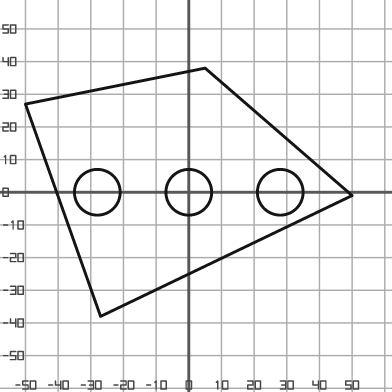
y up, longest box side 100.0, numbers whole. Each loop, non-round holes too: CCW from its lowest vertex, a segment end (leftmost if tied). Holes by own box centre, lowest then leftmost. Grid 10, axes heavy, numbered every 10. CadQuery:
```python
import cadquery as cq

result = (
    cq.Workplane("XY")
    .moveTo(-27.0, -38.0)
    .lineTo(50.0, -1.0)
    .lineTo(5.0, 38.0)
    .lineTo(-50.0, 27.0)
    .close()
    .moveTo(-28.0, 0.0)
    .circle(7.0)
    .moveTo(0.0, 0.0)
    .circle(7.0)
    .moveTo(28.0, 0.0)
    .circle(7.0)
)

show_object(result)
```